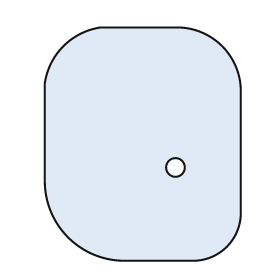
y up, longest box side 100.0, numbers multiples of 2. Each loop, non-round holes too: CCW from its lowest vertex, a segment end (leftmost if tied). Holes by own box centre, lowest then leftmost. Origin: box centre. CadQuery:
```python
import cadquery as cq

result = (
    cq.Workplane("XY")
    .moveTo(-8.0, -50.0)
    .lineTo(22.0, -50.0)
    .threePointArc((36.0, -44.0), (42.0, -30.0))
    .lineTo(42.0, 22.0)
    .threePointArc((34.0, 42.0), (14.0, 50.0))
    .lineTo(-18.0, 50.0)
    .threePointArc((-34.0, 42.0), (-42.0, 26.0))
    .lineTo(-42.0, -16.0)
    .threePointArc((-32.0, -40.0), (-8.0, -50.0))
    .close()
    .moveTo(14.0, -10.0)
    .circle(4.0)
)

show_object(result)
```